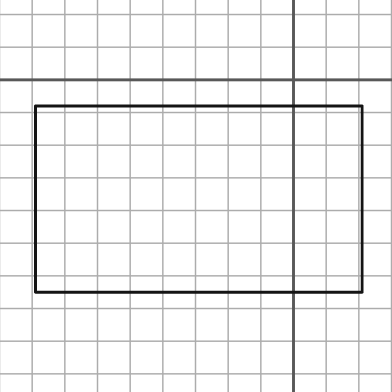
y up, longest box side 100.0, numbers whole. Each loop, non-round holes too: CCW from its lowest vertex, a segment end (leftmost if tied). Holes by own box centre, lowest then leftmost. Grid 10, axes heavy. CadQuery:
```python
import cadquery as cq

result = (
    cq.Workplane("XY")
    .moveTo(-79.0, -65.0)
    .lineTo(21.0, -65.0)
    .lineTo(21.0, -8.0)
    .lineTo(-79.0, -8.0)
    .close()
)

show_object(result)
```